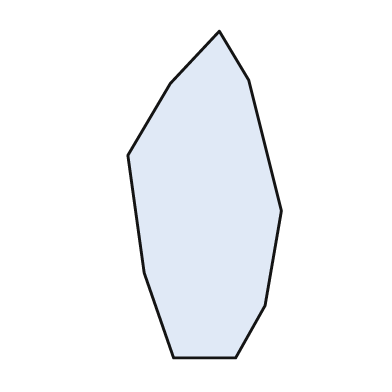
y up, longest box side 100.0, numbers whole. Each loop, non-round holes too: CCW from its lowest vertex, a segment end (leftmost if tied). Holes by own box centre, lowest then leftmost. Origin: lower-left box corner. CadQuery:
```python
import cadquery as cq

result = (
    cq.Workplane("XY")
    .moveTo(14.0, 0.0)
    .lineTo(33.0, 0.0)
    .lineTo(42.0, 16.0)
    .lineTo(47.0, 45.0)
    .lineTo(37.0, 85.0)
    .lineTo(28.0, 100.0)
    .lineTo(13.0, 84.0)
    .lineTo(0.0, 62.0)
    .lineTo(5.0, 26.0)
    .close()
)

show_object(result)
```